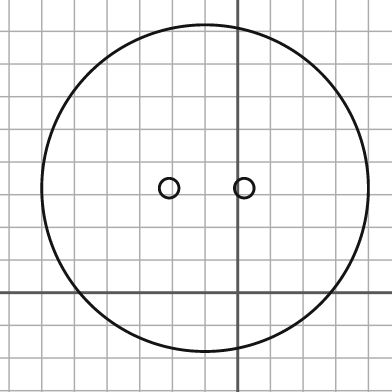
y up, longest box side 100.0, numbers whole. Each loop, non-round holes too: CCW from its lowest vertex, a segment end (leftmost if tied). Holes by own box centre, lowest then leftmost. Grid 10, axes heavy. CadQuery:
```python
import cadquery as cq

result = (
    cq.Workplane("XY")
    .moveTo(-10.0, 32.0)
    .circle(50.0)
    .moveTo(-21.0, 32.0)
    .circle(3.0)
    .moveTo(2.0, 32.0)
    .circle(3.0)
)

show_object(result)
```